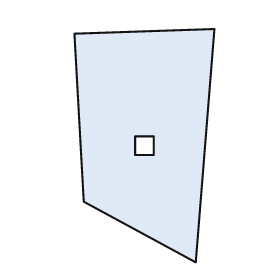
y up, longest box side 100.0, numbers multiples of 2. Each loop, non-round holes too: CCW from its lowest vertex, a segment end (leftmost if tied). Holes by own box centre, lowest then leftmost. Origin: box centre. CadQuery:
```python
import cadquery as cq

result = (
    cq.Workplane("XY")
    .moveTo(22.0, -50.0)
    .lineTo(30.0, 50.0)
    .lineTo(-30.0, 48.0)
    .lineTo(-26.0, -24.0)
    .close()
    .moveTo(-4.0, -4.0)
    .lineTo(4.0, -4.0)
    .lineTo(4.0, 4.0)
    .lineTo(-4.0, 4.0)
    .close()
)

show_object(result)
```